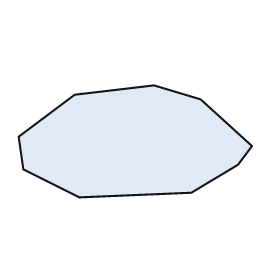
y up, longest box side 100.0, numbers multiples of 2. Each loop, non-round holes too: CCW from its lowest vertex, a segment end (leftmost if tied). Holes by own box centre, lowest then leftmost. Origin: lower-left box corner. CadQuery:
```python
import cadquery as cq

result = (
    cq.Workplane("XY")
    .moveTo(26.0, 0.0)
    .lineTo(74.0, 2.0)
    .lineTo(94.0, 14.0)
    .lineTo(100.0, 22.0)
    .lineTo(78.0, 42.0)
    .lineTo(58.0, 48.0)
    .lineTo(24.0, 44.0)
    .lineTo(0.0, 26.0)
    .lineTo(2.0, 12.0)
    .close()
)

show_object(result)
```